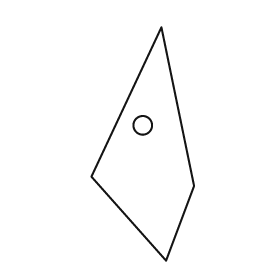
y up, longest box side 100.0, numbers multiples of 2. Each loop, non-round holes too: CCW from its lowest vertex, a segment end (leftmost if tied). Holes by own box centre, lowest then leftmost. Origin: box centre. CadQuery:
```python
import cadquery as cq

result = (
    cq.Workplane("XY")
    .moveTo(10.0, -50.0)
    .lineTo(22.0, -18.0)
    .lineTo(8.0, 50.0)
    .lineTo(-22.0, -14.0)
    .close()
    .moveTo(0.0, 8.0)
    .circle(4.0)
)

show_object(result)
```